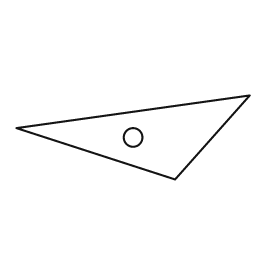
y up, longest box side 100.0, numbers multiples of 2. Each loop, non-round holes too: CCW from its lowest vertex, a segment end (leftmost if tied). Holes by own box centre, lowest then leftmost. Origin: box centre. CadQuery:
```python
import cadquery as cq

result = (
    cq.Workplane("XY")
    .moveTo(18.0, -18.0)
    .lineTo(50.0, 18.0)
    .lineTo(-50.0, 4.0)
    .close()
    .moveTo(0.0, 0.0)
    .circle(4.0)
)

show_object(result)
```